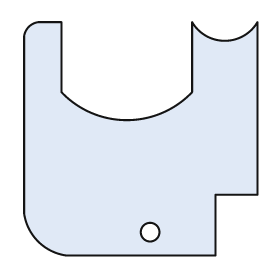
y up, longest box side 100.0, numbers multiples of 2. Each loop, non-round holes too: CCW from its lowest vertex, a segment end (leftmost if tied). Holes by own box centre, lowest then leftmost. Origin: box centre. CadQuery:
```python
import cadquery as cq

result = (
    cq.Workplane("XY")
    .moveTo(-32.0, -50.0)
    .lineTo(32.0, -50.0)
    .lineTo(32.0, -24.0)
    .lineTo(50.0, -24.0)
    .lineTo(50.0, 50.0)
    .threePointArc((36.0, 42.0), (22.0, 50.0))
    .lineTo(22.0, 20.0)
    .threePointArc((-6.0, 8.0), (-34.0, 20.0))
    .lineTo(-34.0, 50.0)
    .lineTo(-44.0, 50.0)
    .threePointArc((-48.0, 48.0), (-50.0, 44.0))
    .lineTo(-50.0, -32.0)
    .threePointArc((-44.0, -44.0), (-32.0, -50.0))
    .close()
    .moveTo(4.0, -40.0)
    .circle(4.0)
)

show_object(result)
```